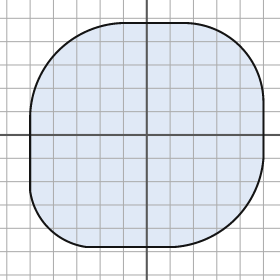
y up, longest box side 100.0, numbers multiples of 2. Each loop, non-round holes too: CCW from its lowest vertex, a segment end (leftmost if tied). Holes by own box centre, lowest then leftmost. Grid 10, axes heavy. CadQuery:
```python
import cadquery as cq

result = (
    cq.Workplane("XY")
    .moveTo(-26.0, -48.0)
    .lineTo(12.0, -48.0)
    .threePointArc((38.0, -36.0), (50.0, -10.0))
    .lineTo(50.0, 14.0)
    .threePointArc((40.0, 38.0), (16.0, 48.0))
    .lineTo(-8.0, 48.0)
    .threePointArc((-38.0, 36.0), (-50.0, 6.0))
    .lineTo(-50.0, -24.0)
    .threePointArc((-42.0, -40.0), (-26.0, -48.0))
    .close()
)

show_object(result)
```